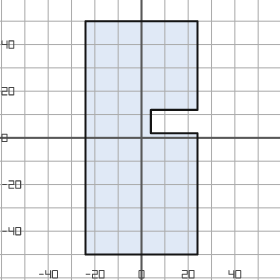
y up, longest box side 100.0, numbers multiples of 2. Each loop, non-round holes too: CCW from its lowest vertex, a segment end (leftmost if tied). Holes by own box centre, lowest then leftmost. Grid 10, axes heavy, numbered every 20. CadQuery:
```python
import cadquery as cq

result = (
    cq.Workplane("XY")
    .moveTo(-24.0, -50.0)
    .lineTo(24.0, -50.0)
    .lineTo(24.0, 2.0)
    .lineTo(4.0, 2.0)
    .lineTo(4.0, 12.0)
    .lineTo(24.0, 12.0)
    .lineTo(24.0, 50.0)
    .lineTo(-24.0, 50.0)
    .close()
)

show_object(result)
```